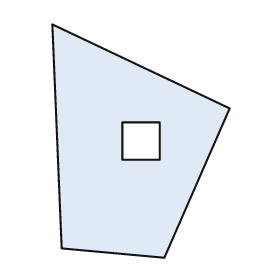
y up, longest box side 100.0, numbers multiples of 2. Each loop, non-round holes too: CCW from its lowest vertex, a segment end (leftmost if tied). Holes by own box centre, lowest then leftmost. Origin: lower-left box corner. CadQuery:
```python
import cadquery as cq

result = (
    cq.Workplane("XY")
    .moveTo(48.0, 0.0)
    .lineTo(76.0, 64.0)
    .lineTo(0.0, 100.0)
    .lineTo(4.0, 4.0)
    .close()
    .moveTo(30.0, 42.0)
    .lineTo(46.0, 42.0)
    .lineTo(46.0, 58.0)
    .lineTo(30.0, 58.0)
    .close()
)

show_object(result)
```